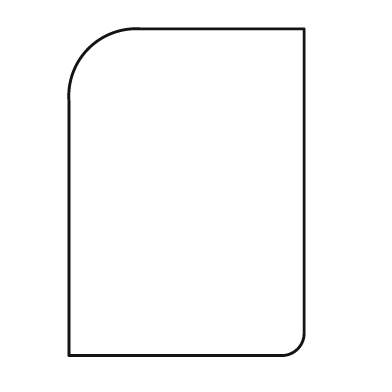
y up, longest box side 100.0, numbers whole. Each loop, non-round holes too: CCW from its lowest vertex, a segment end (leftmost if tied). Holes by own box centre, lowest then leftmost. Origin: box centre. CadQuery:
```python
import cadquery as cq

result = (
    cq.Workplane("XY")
    .moveTo(-36.0, -50.0)
    .lineTo(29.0, -50.0)
    .threePointArc((34.0, -48.0), (36.0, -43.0))
    .lineTo(36.0, 50.0)
    .lineTo(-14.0, 50.0)
    .threePointArc((-30.0, 44.0), (-36.0, 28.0))
    .close()
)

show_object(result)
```